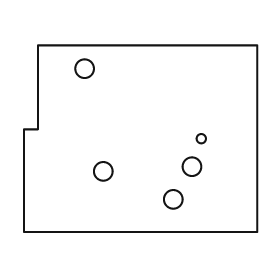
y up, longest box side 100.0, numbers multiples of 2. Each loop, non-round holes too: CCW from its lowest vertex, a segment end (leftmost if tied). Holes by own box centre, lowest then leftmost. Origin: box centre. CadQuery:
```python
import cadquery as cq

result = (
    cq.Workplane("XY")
    .moveTo(-50.0, -40.0)
    .lineTo(50.0, -40.0)
    .lineTo(50.0, 40.0)
    .lineTo(-44.0, 40.0)
    .lineTo(-44.0, 4.0)
    .lineTo(-50.0, 4.0)
    .close()
    .moveTo(14.0, -26.0)
    .circle(4.0)
    .moveTo(-16.0, -14.0)
    .circle(4.0)
    .moveTo(22.0, -12.0)
    .circle(4.0)
    .moveTo(26.0, 0.0)
    .circle(2.0)
    .moveTo(-24.0, 30.0)
    .circle(4.0)
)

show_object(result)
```